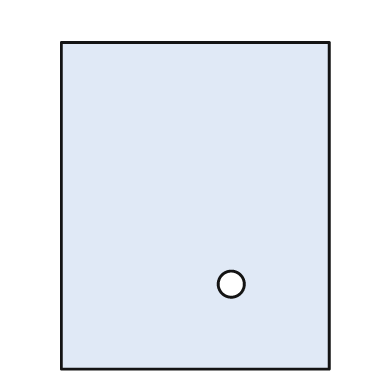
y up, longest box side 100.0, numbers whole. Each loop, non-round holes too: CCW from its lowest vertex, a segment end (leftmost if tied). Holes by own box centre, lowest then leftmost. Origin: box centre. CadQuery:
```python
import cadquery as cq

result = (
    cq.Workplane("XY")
    .moveTo(-41.0, -50.0)
    .lineTo(41.0, -50.0)
    .lineTo(41.0, 50.0)
    .lineTo(-41.0, 50.0)
    .close()
    .moveTo(11.0, -24.0)
    .circle(4.0)
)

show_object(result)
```